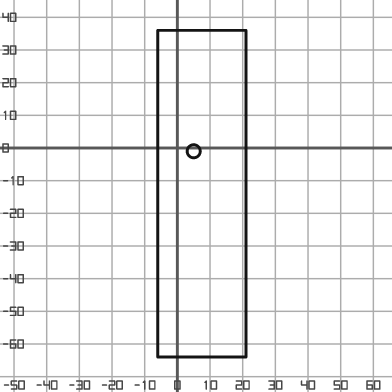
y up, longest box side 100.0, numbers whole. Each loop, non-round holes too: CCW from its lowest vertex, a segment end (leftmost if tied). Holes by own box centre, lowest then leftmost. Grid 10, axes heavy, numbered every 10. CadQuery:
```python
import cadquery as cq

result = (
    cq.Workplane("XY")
    .moveTo(-6.0, -64.0)
    .lineTo(21.0, -64.0)
    .lineTo(21.0, 36.0)
    .lineTo(-6.0, 36.0)
    .close()
    .moveTo(5.0, -1.0)
    .circle(2.0)
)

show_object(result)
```